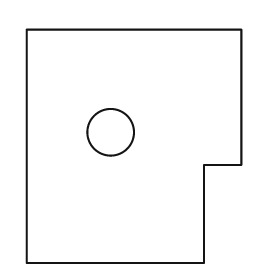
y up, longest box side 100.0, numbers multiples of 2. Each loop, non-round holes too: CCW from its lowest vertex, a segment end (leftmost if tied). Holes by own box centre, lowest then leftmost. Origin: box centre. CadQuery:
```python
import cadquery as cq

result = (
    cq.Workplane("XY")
    .moveTo(-46.0, -50.0)
    .lineTo(30.0, -50.0)
    .lineTo(30.0, -8.0)
    .lineTo(46.0, -8.0)
    .lineTo(46.0, 50.0)
    .lineTo(-46.0, 50.0)
    .close()
    .moveTo(-10.0, 6.0)
    .circle(10.0)
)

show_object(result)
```